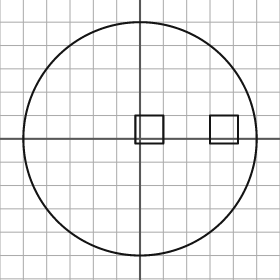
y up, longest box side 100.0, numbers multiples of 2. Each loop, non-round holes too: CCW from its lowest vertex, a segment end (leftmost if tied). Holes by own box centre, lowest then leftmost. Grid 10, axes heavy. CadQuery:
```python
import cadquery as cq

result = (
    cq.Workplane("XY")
    .moveTo(0.0, 0.0)
    .circle(50.0)
    .moveTo(-2.0, -2.0)
    .lineTo(10.0, -2.0)
    .lineTo(10.0, 10.0)
    .lineTo(-2.0, 10.0)
    .close()
    .moveTo(30.0, -2.0)
    .lineTo(42.0, -2.0)
    .lineTo(42.0, 10.0)
    .lineTo(30.0, 10.0)
    .close()
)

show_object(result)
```